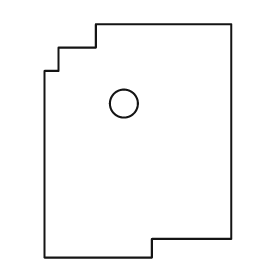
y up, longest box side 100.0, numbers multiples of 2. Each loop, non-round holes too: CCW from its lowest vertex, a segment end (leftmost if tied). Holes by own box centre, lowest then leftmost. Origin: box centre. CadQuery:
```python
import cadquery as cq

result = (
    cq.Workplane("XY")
    .moveTo(-40.0, -50.0)
    .lineTo(6.0, -50.0)
    .lineTo(6.0, -42.0)
    .lineTo(40.0, -42.0)
    .lineTo(40.0, 50.0)
    .lineTo(-18.0, 50.0)
    .lineTo(-18.0, 40.0)
    .lineTo(-34.0, 40.0)
    .lineTo(-34.0, 30.0)
    .lineTo(-40.0, 30.0)
    .close()
    .moveTo(-6.0, 16.0)
    .circle(6.0)
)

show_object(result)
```